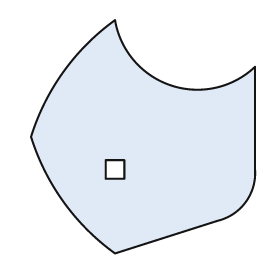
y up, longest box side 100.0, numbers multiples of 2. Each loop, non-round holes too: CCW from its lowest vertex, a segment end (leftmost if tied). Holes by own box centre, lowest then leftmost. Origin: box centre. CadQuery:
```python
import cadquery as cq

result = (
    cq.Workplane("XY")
    .moveTo(-12.0, -50.0)
    .lineTo(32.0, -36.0)
    .threePointArc((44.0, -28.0), (48.0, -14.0))
    .lineTo(48.0, 30.0)
    .threePointArc((12.0, 22.0), (-12.0, 50.0))
    .threePointArc((-34.0, 28.0), (-48.0, 0.0))
    .threePointArc((-34.0, -28.0), (-12.0, -50.0))
    .close()
    .moveTo(-16.0, -18.0)
    .lineTo(-8.0, -18.0)
    .lineTo(-8.0, -10.0)
    .lineTo(-16.0, -10.0)
    .close()
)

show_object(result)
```